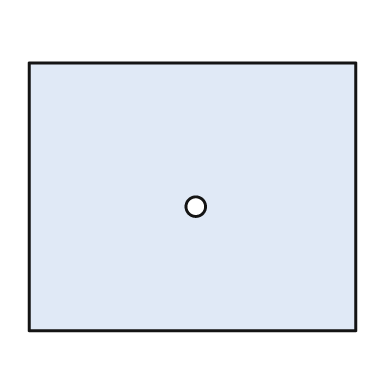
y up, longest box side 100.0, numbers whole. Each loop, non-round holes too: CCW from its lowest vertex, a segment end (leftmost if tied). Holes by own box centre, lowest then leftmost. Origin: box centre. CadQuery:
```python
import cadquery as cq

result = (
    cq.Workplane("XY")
    .moveTo(-50.0, -41.0)
    .lineTo(50.0, -41.0)
    .lineTo(50.0, 41.0)
    .lineTo(-50.0, 41.0)
    .close()
    .moveTo(1.0, -3.0)
    .circle(3.0)
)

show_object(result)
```